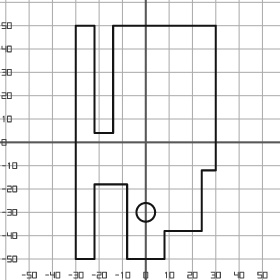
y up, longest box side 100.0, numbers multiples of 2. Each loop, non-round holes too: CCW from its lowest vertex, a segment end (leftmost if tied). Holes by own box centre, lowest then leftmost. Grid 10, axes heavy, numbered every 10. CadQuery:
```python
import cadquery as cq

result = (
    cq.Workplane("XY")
    .moveTo(-30.0, -50.0)
    .lineTo(-22.0, -50.0)
    .lineTo(-22.0, -18.0)
    .lineTo(-8.0, -18.0)
    .lineTo(-8.0, -50.0)
    .lineTo(8.0, -50.0)
    .lineTo(8.0, -38.0)
    .lineTo(24.0, -38.0)
    .lineTo(24.0, -12.0)
    .lineTo(30.0, -12.0)
    .lineTo(30.0, 50.0)
    .lineTo(-14.0, 50.0)
    .lineTo(-14.0, 4.0)
    .lineTo(-22.0, 4.0)
    .lineTo(-22.0, 50.0)
    .lineTo(-30.0, 50.0)
    .close()
    .moveTo(0.0, -30.0)
    .circle(4.0)
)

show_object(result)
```